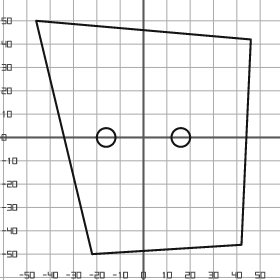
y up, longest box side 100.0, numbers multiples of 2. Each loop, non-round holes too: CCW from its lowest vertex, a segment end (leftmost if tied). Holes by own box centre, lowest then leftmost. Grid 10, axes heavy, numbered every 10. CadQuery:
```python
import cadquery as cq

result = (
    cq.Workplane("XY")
    .moveTo(-22.0, -50.0)
    .lineTo(42.0, -46.0)
    .lineTo(46.0, 42.0)
    .lineTo(-46.0, 50.0)
    .close()
    .moveTo(-16.0, 0.0)
    .circle(4.0)
    .moveTo(16.0, 0.0)
    .circle(4.0)
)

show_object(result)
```